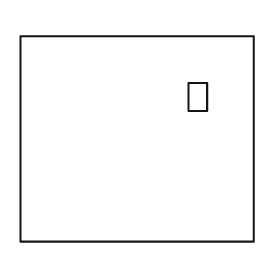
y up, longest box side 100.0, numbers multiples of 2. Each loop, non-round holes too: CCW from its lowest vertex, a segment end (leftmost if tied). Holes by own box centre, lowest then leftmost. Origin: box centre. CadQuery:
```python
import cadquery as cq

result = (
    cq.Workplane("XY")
    .moveTo(-50.0, -44.0)
    .lineTo(50.0, -44.0)
    .lineTo(50.0, 44.0)
    .lineTo(-50.0, 44.0)
    .close()
    .moveTo(22.0, 12.0)
    .lineTo(30.0, 12.0)
    .lineTo(30.0, 24.0)
    .lineTo(22.0, 24.0)
    .close()
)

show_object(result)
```